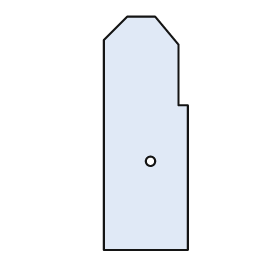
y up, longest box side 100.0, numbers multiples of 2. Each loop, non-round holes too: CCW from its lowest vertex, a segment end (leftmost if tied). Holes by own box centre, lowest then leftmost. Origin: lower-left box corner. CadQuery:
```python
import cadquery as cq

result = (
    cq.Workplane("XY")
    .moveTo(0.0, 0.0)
    .lineTo(36.0, 0.0)
    .lineTo(36.0, 62.0)
    .lineTo(32.0, 62.0)
    .lineTo(32.0, 88.0)
    .lineTo(22.0, 100.0)
    .lineTo(10.0, 100.0)
    .lineTo(0.0, 90.0)
    .close()
    .moveTo(20.0, 38.0)
    .circle(2.0)
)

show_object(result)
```